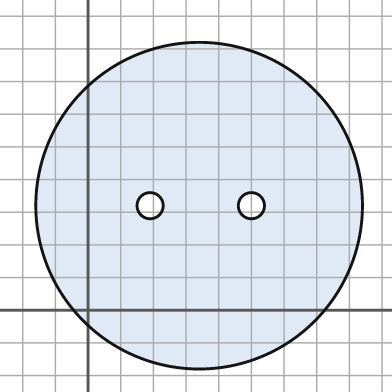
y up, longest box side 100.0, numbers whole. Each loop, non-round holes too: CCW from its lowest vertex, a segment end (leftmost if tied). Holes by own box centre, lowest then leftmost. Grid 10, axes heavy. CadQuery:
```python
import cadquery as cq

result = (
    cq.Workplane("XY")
    .moveTo(34.0, 32.0)
    .circle(50.0)
    .moveTo(19.0, 32.0)
    .circle(4.0)
    .moveTo(50.0, 32.0)
    .circle(4.0)
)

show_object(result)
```